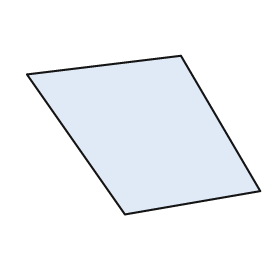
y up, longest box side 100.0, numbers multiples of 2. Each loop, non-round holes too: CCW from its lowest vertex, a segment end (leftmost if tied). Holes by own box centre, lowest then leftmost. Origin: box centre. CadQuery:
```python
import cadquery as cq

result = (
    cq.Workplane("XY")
    .moveTo(-8.0, -34.0)
    .lineTo(50.0, -24.0)
    .lineTo(16.0, 34.0)
    .lineTo(-50.0, 26.0)
    .close()
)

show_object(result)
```